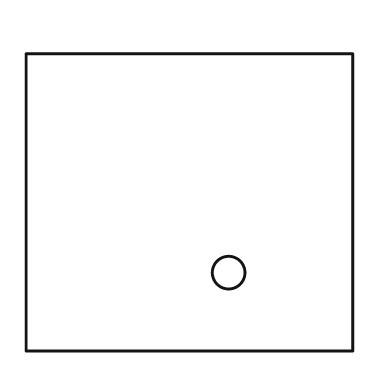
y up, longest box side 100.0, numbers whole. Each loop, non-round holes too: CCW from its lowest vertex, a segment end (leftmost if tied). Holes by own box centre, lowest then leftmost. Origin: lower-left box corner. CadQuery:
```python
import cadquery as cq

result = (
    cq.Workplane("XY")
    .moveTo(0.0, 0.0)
    .lineTo(100.0, 0.0)
    .lineTo(100.0, 91.0)
    .lineTo(0.0, 91.0)
    .close()
    .moveTo(62.0, 24.0)
    .circle(5.0)
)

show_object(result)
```